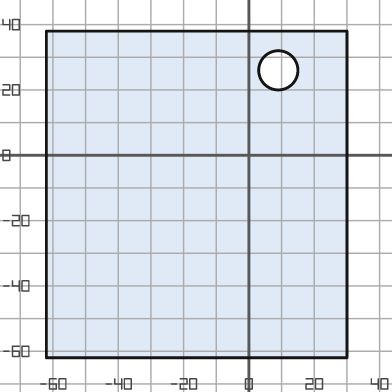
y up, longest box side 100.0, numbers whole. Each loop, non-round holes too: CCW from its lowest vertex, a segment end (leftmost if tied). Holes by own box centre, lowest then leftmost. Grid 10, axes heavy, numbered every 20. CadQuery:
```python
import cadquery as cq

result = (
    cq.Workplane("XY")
    .moveTo(-62.0, -62.0)
    .lineTo(30.0, -62.0)
    .lineTo(30.0, 38.0)
    .lineTo(-62.0, 38.0)
    .close()
    .moveTo(9.0, 26.0)
    .circle(6.0)
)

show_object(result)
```